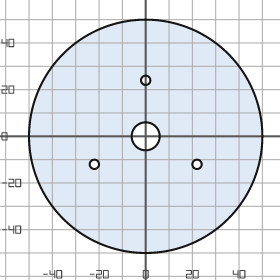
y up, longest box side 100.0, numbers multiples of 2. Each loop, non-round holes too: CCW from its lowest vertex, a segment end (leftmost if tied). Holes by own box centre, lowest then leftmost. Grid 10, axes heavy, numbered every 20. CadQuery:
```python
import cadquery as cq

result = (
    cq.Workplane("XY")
    .moveTo(0.0, 0.0)
    .circle(50.0)
    .moveTo(-22.0, -12.0)
    .circle(2.0)
    .moveTo(22.0, -12.0)
    .circle(2.0)
    .moveTo(0.0, 0.0)
    .circle(6.0)
    .moveTo(0.0, 24.0)
    .circle(2.0)
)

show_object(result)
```